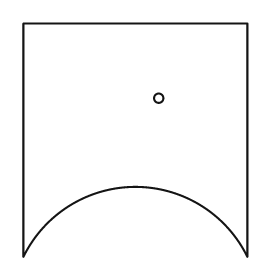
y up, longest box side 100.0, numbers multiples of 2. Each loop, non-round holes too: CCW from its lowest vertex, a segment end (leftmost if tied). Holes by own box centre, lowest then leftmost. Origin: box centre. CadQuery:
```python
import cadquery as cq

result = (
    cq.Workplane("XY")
    .moveTo(-48.0, -50.0)
    .threePointArc((0.0, -20.0), (48.0, -50.0))
    .lineTo(48.0, 50.0)
    .lineTo(-48.0, 50.0)
    .close()
    .moveTo(10.0, 18.0)
    .circle(2.0)
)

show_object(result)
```